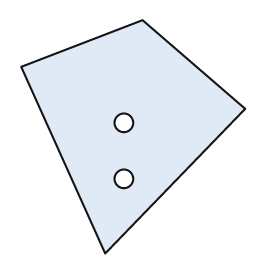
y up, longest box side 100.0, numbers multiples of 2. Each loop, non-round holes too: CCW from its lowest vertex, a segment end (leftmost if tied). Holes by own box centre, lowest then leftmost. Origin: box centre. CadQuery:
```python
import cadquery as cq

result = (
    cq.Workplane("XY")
    .moveTo(-12.0, -50.0)
    .lineTo(48.0, 12.0)
    .lineTo(4.0, 50.0)
    .lineTo(-48.0, 30.0)
    .close()
    .moveTo(-4.0, -18.0)
    .circle(4.0)
    .moveTo(-4.0, 6.0)
    .circle(4.0)
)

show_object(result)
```